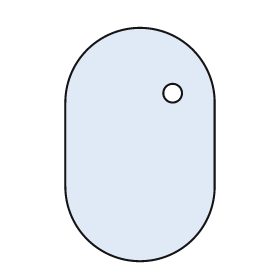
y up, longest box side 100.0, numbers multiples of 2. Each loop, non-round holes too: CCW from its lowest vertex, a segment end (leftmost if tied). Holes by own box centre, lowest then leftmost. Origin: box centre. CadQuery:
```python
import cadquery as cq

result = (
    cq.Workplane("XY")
    .moveTo(-32.0, -18.0)
    .threePointArc((0.0, -50.0), (32.0, -18.0))
    .lineTo(32.0, 18.0)
    .threePointArc((0.0, 50.0), (-32.0, 18.0))
    .close()
    .moveTo(14.0, 22.0)
    .circle(4.0)
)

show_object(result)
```